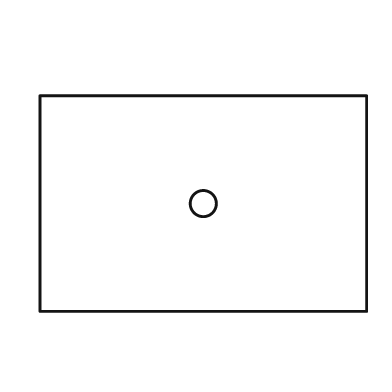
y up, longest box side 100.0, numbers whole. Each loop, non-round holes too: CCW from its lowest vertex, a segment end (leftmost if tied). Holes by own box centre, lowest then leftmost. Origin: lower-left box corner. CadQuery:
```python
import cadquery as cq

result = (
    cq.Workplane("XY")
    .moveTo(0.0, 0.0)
    .lineTo(100.0, 0.0)
    .lineTo(100.0, 66.0)
    .lineTo(0.0, 66.0)
    .close()
    .moveTo(50.0, 33.0)
    .circle(4.0)
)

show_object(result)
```